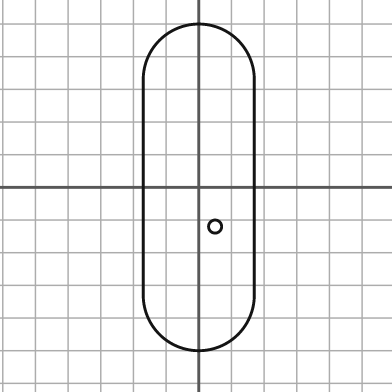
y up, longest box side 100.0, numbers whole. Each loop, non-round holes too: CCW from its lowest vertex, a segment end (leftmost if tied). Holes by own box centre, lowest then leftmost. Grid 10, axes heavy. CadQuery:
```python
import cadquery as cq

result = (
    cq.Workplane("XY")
    .moveTo(-17.0, -33.0)
    .threePointArc((0.0, -50.0), (17.0, -33.0))
    .lineTo(17.0, 33.0)
    .threePointArc((0.0, 50.0), (-17.0, 33.0))
    .close()
    .moveTo(5.0, -12.0)
    .circle(2.0)
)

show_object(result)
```